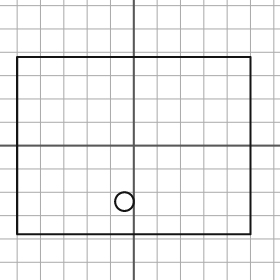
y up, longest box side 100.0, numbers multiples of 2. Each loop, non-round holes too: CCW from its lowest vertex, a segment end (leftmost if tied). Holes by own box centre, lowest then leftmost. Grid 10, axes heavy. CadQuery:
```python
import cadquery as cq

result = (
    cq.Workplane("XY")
    .moveTo(-50.0, -38.0)
    .lineTo(50.0, -38.0)
    .lineTo(50.0, 38.0)
    .lineTo(-50.0, 38.0)
    .close()
    .moveTo(-4.0, -24.0)
    .circle(4.0)
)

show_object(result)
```